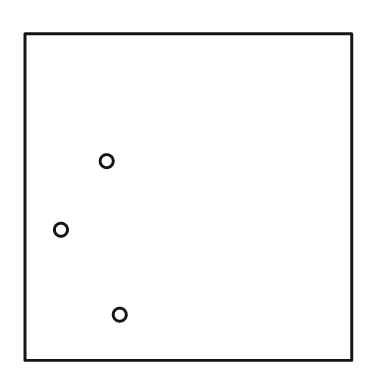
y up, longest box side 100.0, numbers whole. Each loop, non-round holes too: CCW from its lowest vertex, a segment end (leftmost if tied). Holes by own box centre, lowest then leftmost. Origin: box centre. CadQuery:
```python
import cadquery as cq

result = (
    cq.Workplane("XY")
    .moveTo(-50.0, -50.0)
    .lineTo(50.0, -50.0)
    .lineTo(50.0, 50.0)
    .lineTo(-50.0, 50.0)
    .close()
    .moveTo(-21.0, -36.0)
    .circle(2.0)
    .moveTo(-39.0, -10.0)
    .circle(2.0)
    .moveTo(-25.0, 11.0)
    .circle(2.0)
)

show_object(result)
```